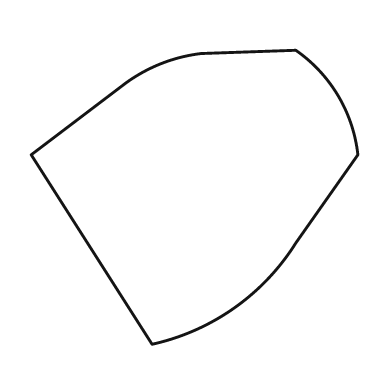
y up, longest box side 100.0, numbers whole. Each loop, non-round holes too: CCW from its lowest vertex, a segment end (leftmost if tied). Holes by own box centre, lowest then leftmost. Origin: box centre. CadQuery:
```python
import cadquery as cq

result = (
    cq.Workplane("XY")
    .moveTo(-13.0, -45.0)
    .threePointArc((12.0, -34.0), (31.0, -14.0))
    .lineTo(50.0, 13.0)
    .threePointArc((44.0, 31.0), (31.0, 45.0))
    .lineTo(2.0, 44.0)
    .threePointArc((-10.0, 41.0), (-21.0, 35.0))
    .lineTo(-50.0, 13.0)
    .close()
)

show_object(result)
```